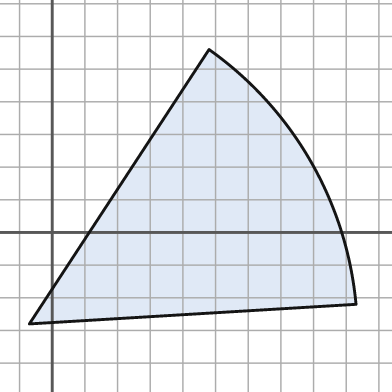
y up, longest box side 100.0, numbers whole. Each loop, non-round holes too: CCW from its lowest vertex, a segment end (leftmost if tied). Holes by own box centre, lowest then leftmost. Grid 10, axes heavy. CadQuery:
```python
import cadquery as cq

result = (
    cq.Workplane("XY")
    .moveTo(-7.0, -28.0)
    .lineTo(93.0, -22.0)
    .threePointArc((79.0, 22.0), (48.0, 56.0))
    .close()
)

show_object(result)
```